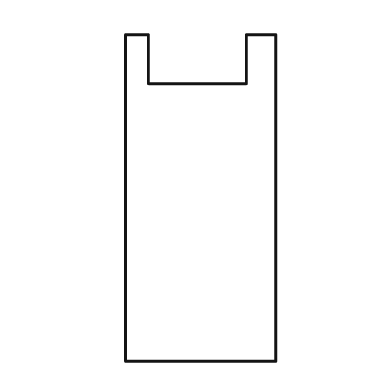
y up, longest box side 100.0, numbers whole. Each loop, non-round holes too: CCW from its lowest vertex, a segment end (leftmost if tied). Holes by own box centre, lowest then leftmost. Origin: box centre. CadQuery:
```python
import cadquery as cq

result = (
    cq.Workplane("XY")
    .moveTo(-23.0, -50.0)
    .lineTo(23.0, -50.0)
    .lineTo(23.0, 50.0)
    .lineTo(14.0, 50.0)
    .lineTo(14.0, 35.0)
    .lineTo(-16.0, 35.0)
    .lineTo(-16.0, 50.0)
    .lineTo(-23.0, 50.0)
    .close()
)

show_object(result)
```